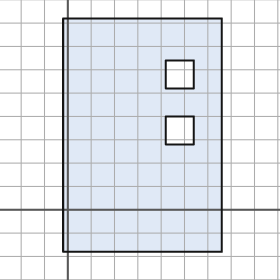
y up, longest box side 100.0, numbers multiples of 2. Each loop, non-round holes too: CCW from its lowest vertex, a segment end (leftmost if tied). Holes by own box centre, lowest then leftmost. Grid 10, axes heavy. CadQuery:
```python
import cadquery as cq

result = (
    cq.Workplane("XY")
    .moveTo(-2.0, -18.0)
    .lineTo(66.0, -18.0)
    .lineTo(66.0, 82.0)
    .lineTo(-2.0, 82.0)
    .close()
    .moveTo(42.0, 28.0)
    .lineTo(54.0, 28.0)
    .lineTo(54.0, 40.0)
    .lineTo(42.0, 40.0)
    .close()
    .moveTo(42.0, 52.0)
    .lineTo(54.0, 52.0)
    .lineTo(54.0, 64.0)
    .lineTo(42.0, 64.0)
    .close()
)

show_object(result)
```